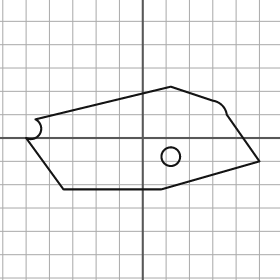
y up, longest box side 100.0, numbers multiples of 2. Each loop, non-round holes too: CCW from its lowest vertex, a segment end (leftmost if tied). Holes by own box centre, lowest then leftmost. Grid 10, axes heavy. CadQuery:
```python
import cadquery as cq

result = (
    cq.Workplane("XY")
    .moveTo(-34.0, -22.0)
    .lineTo(8.0, -22.0)
    .lineTo(50.0, -10.0)
    .lineTo(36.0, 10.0)
    .threePointArc((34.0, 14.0), (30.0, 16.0))
    .lineTo(12.0, 22.0)
    .lineTo(-46.0, 8.0)
    .threePointArc((-44.0, 2.0), (-50.0, 0.0))
    .close()
    .moveTo(12.0, -8.0)
    .circle(4.0)
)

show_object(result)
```